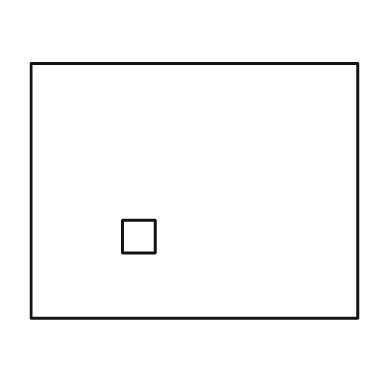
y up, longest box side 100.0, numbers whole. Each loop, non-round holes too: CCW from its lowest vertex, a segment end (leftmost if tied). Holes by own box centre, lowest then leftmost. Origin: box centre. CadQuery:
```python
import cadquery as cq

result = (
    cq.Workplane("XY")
    .moveTo(-50.0, -39.0)
    .lineTo(50.0, -39.0)
    .lineTo(50.0, 39.0)
    .lineTo(-50.0, 39.0)
    .close()
    .moveTo(-22.0, -19.0)
    .lineTo(-12.0, -19.0)
    .lineTo(-12.0, -9.0)
    .lineTo(-22.0, -9.0)
    .close()
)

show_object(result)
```